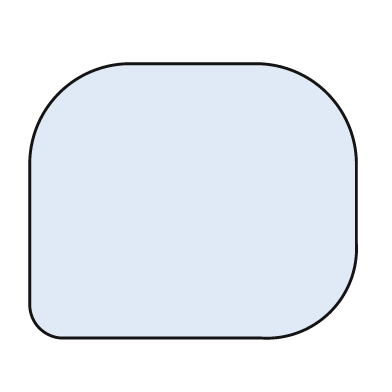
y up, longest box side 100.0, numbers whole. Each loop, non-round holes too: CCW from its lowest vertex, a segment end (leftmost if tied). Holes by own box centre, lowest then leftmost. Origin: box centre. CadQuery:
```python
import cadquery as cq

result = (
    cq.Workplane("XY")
    .moveTo(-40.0, -42.0)
    .lineTo(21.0, -42.0)
    .threePointArc((42.0, -34.0), (50.0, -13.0))
    .lineTo(50.0, 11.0)
    .threePointArc((41.0, 33.0), (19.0, 42.0))
    .lineTo(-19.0, 42.0)
    .threePointArc((-41.0, 33.0), (-50.0, 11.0))
    .lineTo(-50.0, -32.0)
    .threePointArc((-47.0, -39.0), (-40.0, -42.0))
    .close()
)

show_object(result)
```